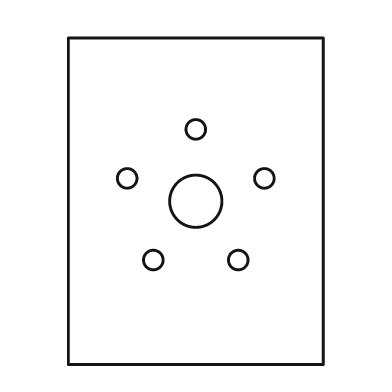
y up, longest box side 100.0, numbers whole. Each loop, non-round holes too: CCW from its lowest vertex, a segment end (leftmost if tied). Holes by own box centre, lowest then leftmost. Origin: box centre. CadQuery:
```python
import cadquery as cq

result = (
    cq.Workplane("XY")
    .moveTo(-39.0, -50.0)
    .lineTo(39.0, -50.0)
    .lineTo(39.0, 50.0)
    .lineTo(-39.0, 50.0)
    .close()
    .moveTo(-13.0, -18.0)
    .circle(3.0)
    .moveTo(13.0, -18.0)
    .circle(3.0)
    .moveTo(0.0, 0.0)
    .circle(8.0)
    .moveTo(-21.0, 7.0)
    .circle(3.0)
    .moveTo(21.0, 7.0)
    .circle(3.0)
    .moveTo(0.0, 22.0)
    .circle(3.0)
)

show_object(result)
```